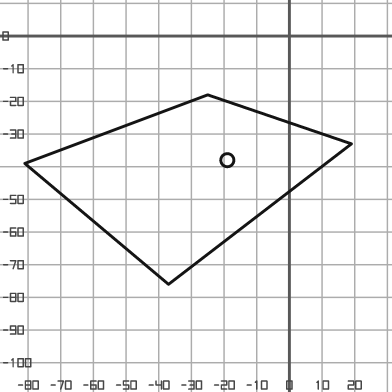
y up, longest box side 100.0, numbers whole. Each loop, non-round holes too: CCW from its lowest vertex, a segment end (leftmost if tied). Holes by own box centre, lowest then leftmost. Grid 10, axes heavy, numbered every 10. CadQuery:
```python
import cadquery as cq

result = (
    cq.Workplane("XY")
    .moveTo(-37.0, -76.0)
    .lineTo(19.0, -33.0)
    .lineTo(-25.0, -18.0)
    .lineTo(-81.0, -39.0)
    .close()
    .moveTo(-19.0, -38.0)
    .circle(2.0)
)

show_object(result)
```